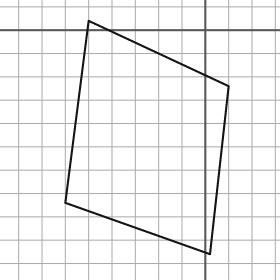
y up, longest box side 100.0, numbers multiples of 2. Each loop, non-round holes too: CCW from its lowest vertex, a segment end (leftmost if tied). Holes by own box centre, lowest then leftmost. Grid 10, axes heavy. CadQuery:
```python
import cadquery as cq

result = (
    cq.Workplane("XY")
    .moveTo(2.0, -96.0)
    .lineTo(10.0, -24.0)
    .lineTo(-50.0, 4.0)
    .lineTo(-60.0, -74.0)
    .close()
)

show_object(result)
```